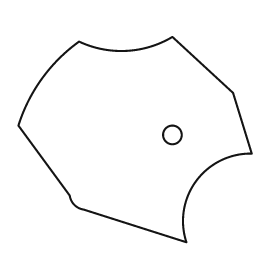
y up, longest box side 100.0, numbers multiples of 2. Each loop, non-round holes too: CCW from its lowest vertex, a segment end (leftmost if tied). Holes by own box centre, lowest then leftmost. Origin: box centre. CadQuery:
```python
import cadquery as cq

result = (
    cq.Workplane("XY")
    .moveTo(22.0, -44.0)
    .threePointArc((26.0, -18.0), (50.0, -6.0))
    .lineTo(42.0, 20.0)
    .lineTo(16.0, 44.0)
    .threePointArc((-4.0, 38.0), (-24.0, 42.0))
    .threePointArc((-40.0, 26.0), (-50.0, 6.0))
    .lineTo(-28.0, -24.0)
    .threePointArc((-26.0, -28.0), (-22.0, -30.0))
    .close()
    .moveTo(16.0, 2.0)
    .circle(4.0)
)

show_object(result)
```